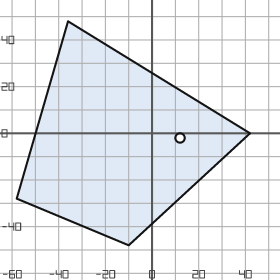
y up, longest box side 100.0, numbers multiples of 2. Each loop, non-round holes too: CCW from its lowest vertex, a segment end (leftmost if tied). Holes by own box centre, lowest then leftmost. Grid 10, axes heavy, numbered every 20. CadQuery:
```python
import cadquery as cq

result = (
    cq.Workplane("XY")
    .moveTo(-10.0, -48.0)
    .lineTo(42.0, 0.0)
    .lineTo(-36.0, 48.0)
    .lineTo(-58.0, -28.0)
    .close()
    .moveTo(12.0, -2.0)
    .circle(2.0)
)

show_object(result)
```